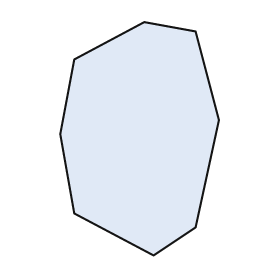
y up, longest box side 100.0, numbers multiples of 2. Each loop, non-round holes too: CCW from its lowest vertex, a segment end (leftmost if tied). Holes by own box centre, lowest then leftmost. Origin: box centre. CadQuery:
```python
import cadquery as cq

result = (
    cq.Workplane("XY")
    .moveTo(6.0, -50.0)
    .lineTo(24.0, -38.0)
    .lineTo(34.0, 8.0)
    .lineTo(24.0, 46.0)
    .lineTo(2.0, 50.0)
    .lineTo(-28.0, 34.0)
    .lineTo(-34.0, 2.0)
    .lineTo(-28.0, -32.0)
    .close()
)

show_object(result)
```